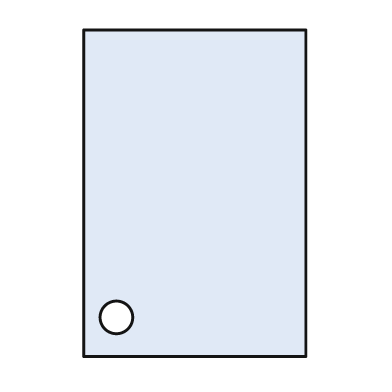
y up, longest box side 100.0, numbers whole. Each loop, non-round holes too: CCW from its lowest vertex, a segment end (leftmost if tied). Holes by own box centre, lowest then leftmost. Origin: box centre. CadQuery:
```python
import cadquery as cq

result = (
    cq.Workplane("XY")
    .moveTo(-34.0, -50.0)
    .lineTo(34.0, -50.0)
    .lineTo(34.0, 50.0)
    .lineTo(-34.0, 50.0)
    .close()
    .moveTo(-24.0, -38.0)
    .circle(5.0)
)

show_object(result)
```